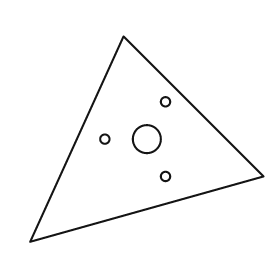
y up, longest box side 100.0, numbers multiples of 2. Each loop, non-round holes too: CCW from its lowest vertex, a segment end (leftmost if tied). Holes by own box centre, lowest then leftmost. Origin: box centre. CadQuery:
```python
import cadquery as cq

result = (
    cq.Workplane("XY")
    .moveTo(-50.0, -44.0)
    .lineTo(50.0, -16.0)
    .lineTo(-10.0, 44.0)
    .close()
    .moveTo(8.0, -16.0)
    .circle(2.0)
    .moveTo(-18.0, 0.0)
    .circle(2.0)
    .moveTo(0.0, 0.0)
    .circle(6.0)
    .moveTo(8.0, 16.0)
    .circle(2.0)
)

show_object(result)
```